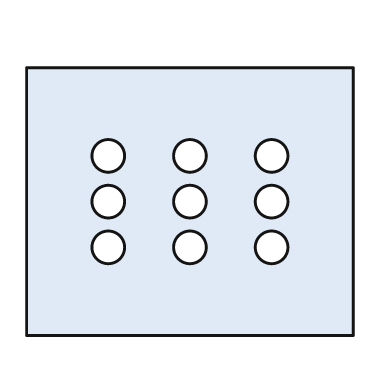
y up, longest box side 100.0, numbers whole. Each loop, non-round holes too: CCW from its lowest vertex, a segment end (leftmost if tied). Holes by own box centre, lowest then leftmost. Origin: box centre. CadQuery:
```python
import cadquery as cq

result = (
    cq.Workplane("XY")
    .moveTo(-50.0, -41.0)
    .lineTo(50.0, -41.0)
    .lineTo(50.0, 41.0)
    .lineTo(-50.0, 41.0)
    .close()
    .moveTo(-25.0, -14.0)
    .circle(5.0)
    .moveTo(0.0, -14.0)
    .circle(5.0)
    .moveTo(25.0, -14.0)
    .circle(5.0)
    .moveTo(-25.0, 0.0)
    .circle(5.0)
    .moveTo(0.0, 0.0)
    .circle(5.0)
    .moveTo(25.0, 0.0)
    .circle(5.0)
    .moveTo(-25.0, 14.0)
    .circle(5.0)
    .moveTo(0.0, 14.0)
    .circle(5.0)
    .moveTo(25.0, 14.0)
    .circle(5.0)
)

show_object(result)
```